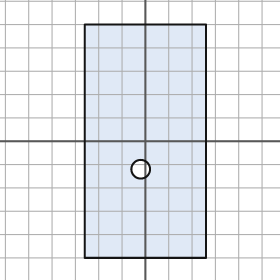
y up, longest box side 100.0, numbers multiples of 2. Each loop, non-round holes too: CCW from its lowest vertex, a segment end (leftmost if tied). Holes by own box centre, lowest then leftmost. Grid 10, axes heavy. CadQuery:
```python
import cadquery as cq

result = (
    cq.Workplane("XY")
    .moveTo(-26.0, -50.0)
    .lineTo(26.0, -50.0)
    .lineTo(26.0, 50.0)
    .lineTo(-26.0, 50.0)
    .close()
    .moveTo(-2.0, -12.0)
    .circle(4.0)
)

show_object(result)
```